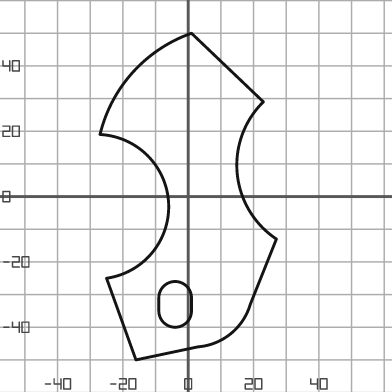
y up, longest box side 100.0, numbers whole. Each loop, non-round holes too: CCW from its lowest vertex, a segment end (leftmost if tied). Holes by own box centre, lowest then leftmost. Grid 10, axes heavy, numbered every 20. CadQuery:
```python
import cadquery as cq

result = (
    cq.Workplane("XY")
    .moveTo(-16.0, -50.0)
    .lineTo(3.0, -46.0)
    .threePointArc((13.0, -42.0), (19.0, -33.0))
    .lineTo(27.0, -13.0)
    .threePointArc((15.0, 7.0), (23.0, 29.0))
    .lineTo(1.0, 50.0)
    .threePointArc((-17.0, 38.0), (-27.0, 19.0))
    .threePointArc((-6.0, -2.0), (-25.0, -25.0))
    .close()
    .moveTo(-9.0, -35.0)
    .threePointArc((-4.0, -40.0), (1.0, -35.0))
    .lineTo(1.0, -31.0)
    .threePointArc((-4.0, -26.0), (-9.0, -31.0))
    .close()
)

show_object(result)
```